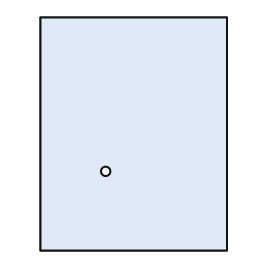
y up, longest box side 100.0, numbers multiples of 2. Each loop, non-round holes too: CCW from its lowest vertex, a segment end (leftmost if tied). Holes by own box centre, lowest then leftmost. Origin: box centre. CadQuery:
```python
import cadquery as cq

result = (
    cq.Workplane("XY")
    .moveTo(-40.0, -50.0)
    .lineTo(40.0, -50.0)
    .lineTo(40.0, 50.0)
    .lineTo(-40.0, 50.0)
    .close()
    .moveTo(-12.0, -16.0)
    .circle(2.0)
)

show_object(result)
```